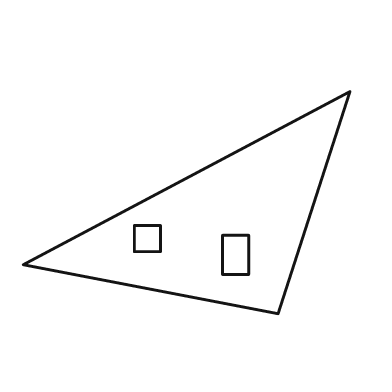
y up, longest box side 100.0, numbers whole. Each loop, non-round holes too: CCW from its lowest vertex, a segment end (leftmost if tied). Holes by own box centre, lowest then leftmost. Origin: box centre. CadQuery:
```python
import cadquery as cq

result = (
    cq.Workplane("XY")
    .moveTo(28.0, -34.0)
    .lineTo(50.0, 34.0)
    .lineTo(-50.0, -19.0)
    .close()
    .moveTo(11.0, -22.0)
    .lineTo(19.0, -22.0)
    .lineTo(19.0, -10.0)
    .lineTo(11.0, -10.0)
    .close()
    .moveTo(-16.0, -15.0)
    .lineTo(-8.0, -15.0)
    .lineTo(-8.0, -7.0)
    .lineTo(-16.0, -7.0)
    .close()
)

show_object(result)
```